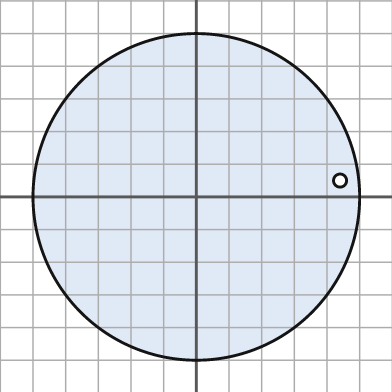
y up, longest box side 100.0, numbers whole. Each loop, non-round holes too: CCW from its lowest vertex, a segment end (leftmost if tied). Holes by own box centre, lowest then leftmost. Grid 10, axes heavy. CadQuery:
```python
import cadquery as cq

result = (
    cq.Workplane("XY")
    .moveTo(0.0, 0.0)
    .circle(50.0)
    .moveTo(44.0, 5.0)
    .circle(2.0)
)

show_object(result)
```